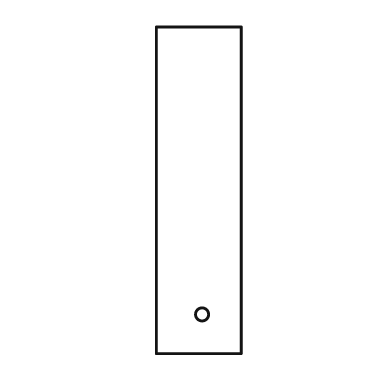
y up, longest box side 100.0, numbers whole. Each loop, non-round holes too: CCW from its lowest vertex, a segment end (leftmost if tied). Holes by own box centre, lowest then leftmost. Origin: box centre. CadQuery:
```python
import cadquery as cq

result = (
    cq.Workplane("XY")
    .moveTo(-13.0, -50.0)
    .lineTo(13.0, -50.0)
    .lineTo(13.0, 50.0)
    .lineTo(-13.0, 50.0)
    .close()
    .moveTo(1.0, -38.0)
    .circle(2.0)
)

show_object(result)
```